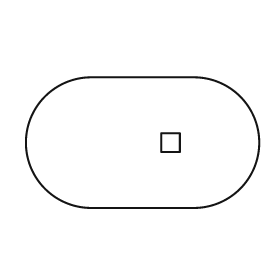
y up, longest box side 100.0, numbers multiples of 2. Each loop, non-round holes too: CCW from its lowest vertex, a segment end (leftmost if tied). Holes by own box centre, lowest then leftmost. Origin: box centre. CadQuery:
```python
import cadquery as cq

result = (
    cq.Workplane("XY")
    .moveTo(-22.0, -28.0)
    .lineTo(22.0, -28.0)
    .threePointArc((50.0, 0.0), (22.0, 28.0))
    .lineTo(-22.0, 28.0)
    .threePointArc((-50.0, 0.0), (-22.0, -28.0))
    .close()
    .moveTo(8.0, -4.0)
    .lineTo(16.0, -4.0)
    .lineTo(16.0, 4.0)
    .lineTo(8.0, 4.0)
    .close()
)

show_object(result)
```